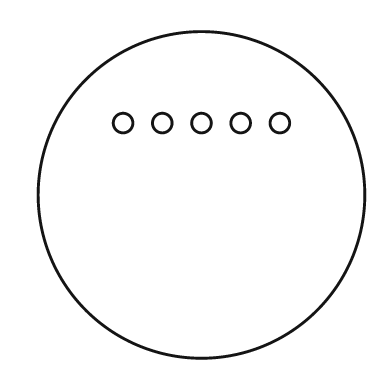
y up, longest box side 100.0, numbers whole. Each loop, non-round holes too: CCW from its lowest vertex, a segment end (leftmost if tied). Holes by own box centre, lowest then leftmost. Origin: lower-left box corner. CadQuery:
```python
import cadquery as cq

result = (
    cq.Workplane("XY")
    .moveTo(50.0, 50.0)
    .circle(50.0)
    .moveTo(26.0, 72.0)
    .circle(3.0)
    .moveTo(38.0, 72.0)
    .circle(3.0)
    .moveTo(50.0, 72.0)
    .circle(3.0)
    .moveTo(62.0, 72.0)
    .circle(3.0)
    .moveTo(74.0, 72.0)
    .circle(3.0)
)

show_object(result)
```